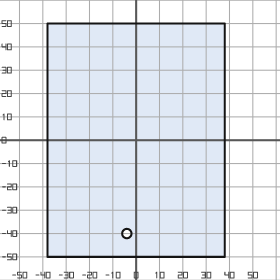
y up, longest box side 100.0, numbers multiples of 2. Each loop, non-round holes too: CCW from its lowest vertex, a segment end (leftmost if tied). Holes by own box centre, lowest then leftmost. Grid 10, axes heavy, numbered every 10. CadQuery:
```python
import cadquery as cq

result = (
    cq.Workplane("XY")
    .moveTo(-38.0, -50.0)
    .lineTo(38.0, -50.0)
    .lineTo(38.0, 50.0)
    .lineTo(-38.0, 50.0)
    .close()
    .moveTo(-4.0, -40.0)
    .circle(2.0)
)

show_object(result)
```